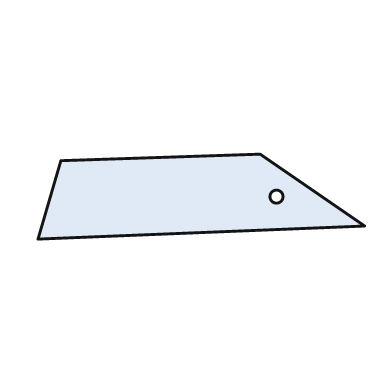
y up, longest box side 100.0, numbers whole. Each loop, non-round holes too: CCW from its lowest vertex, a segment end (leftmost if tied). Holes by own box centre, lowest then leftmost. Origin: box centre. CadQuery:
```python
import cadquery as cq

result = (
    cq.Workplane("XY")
    .moveTo(-50.0, -13.0)
    .lineTo(50.0, -9.0)
    .lineTo(18.0, 13.0)
    .lineTo(-43.0, 11.0)
    .close()
    .moveTo(23.0, 0.0)
    .circle(2.0)
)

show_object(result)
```